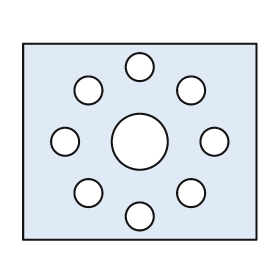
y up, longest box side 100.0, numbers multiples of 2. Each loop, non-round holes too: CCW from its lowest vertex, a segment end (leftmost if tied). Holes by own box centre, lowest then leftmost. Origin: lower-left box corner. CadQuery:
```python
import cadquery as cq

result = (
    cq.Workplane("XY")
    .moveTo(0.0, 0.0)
    .lineTo(100.0, 0.0)
    .lineTo(100.0, 84.0)
    .lineTo(0.0, 84.0)
    .close()
    .moveTo(50.0, 10.0)
    .circle(6.0)
    .moveTo(28.0, 20.0)
    .circle(6.0)
    .moveTo(72.0, 20.0)
    .circle(6.0)
    .moveTo(18.0, 42.0)
    .circle(6.0)
    .moveTo(50.0, 42.0)
    .circle(12.0)
    .moveTo(82.0, 42.0)
    .circle(6.0)
    .moveTo(28.0, 64.0)
    .circle(6.0)
    .moveTo(72.0, 64.0)
    .circle(6.0)
    .moveTo(50.0, 74.0)
    .circle(6.0)
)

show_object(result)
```